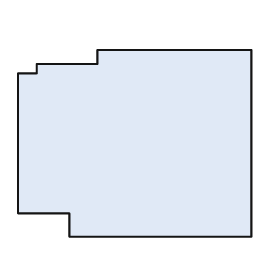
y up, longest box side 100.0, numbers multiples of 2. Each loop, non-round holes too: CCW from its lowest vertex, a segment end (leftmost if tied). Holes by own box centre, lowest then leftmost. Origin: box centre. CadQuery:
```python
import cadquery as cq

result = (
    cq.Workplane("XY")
    .moveTo(-28.0, -40.0)
    .lineTo(50.0, -40.0)
    .lineTo(50.0, 40.0)
    .lineTo(-16.0, 40.0)
    .lineTo(-16.0, 34.0)
    .lineTo(-42.0, 34.0)
    .lineTo(-42.0, 30.0)
    .lineTo(-50.0, 30.0)
    .lineTo(-50.0, -30.0)
    .lineTo(-28.0, -30.0)
    .close()
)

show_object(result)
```